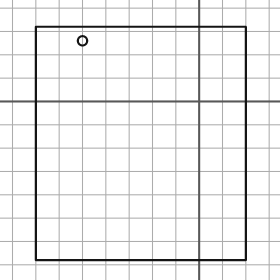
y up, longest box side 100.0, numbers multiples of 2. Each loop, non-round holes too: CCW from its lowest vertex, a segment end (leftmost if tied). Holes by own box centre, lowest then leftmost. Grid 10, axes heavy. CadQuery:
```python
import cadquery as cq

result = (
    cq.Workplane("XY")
    .moveTo(-70.0, -68.0)
    .lineTo(20.0, -68.0)
    .lineTo(20.0, 32.0)
    .lineTo(-70.0, 32.0)
    .close()
    .moveTo(-50.0, 26.0)
    .circle(2.0)
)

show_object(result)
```